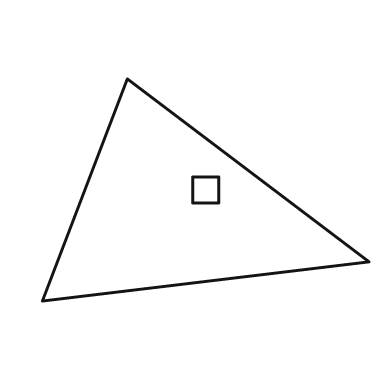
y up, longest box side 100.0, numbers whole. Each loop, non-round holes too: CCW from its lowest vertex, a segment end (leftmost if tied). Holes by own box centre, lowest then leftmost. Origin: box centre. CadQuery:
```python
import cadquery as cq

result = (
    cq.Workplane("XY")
    .moveTo(-50.0, -34.0)
    .lineTo(50.0, -22.0)
    .lineTo(-24.0, 34.0)
    .close()
    .moveTo(-4.0, -4.0)
    .lineTo(4.0, -4.0)
    .lineTo(4.0, 4.0)
    .lineTo(-4.0, 4.0)
    .close()
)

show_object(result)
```